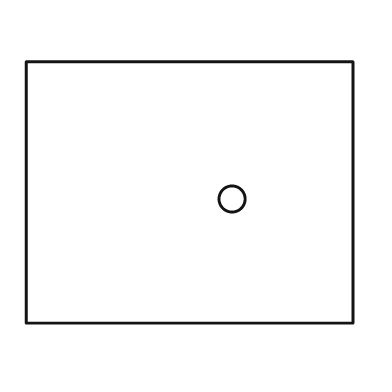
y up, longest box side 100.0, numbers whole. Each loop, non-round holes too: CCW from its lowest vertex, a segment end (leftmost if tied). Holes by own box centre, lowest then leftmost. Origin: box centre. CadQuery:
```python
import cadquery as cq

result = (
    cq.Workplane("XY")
    .moveTo(-50.0, -40.0)
    .lineTo(50.0, -40.0)
    .lineTo(50.0, 40.0)
    .lineTo(-50.0, 40.0)
    .close()
    .moveTo(13.0, -2.0)
    .circle(4.0)
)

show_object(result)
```